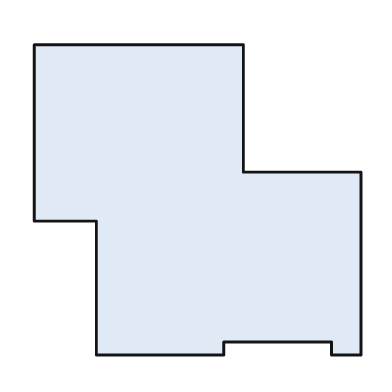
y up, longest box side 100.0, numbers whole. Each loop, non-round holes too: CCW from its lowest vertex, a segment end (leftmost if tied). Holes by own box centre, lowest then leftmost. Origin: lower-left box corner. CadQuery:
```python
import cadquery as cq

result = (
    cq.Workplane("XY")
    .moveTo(19.0, 0.0)
    .lineTo(58.0, 0.0)
    .lineTo(58.0, 4.0)
    .lineTo(91.0, 4.0)
    .lineTo(91.0, 0.0)
    .lineTo(100.0, 0.0)
    .lineTo(100.0, 56.0)
    .lineTo(64.0, 56.0)
    .lineTo(64.0, 95.0)
    .lineTo(0.0, 95.0)
    .lineTo(0.0, 41.0)
    .lineTo(19.0, 41.0)
    .close()
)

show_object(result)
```